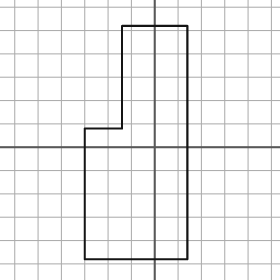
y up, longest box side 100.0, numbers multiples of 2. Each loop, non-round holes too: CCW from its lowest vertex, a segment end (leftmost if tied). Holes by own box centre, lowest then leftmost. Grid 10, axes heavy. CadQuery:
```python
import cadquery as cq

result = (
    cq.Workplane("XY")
    .moveTo(-30.0, -48.0)
    .lineTo(14.0, -48.0)
    .lineTo(14.0, 52.0)
    .lineTo(-14.0, 52.0)
    .lineTo(-14.0, 8.0)
    .lineTo(-30.0, 8.0)
    .close()
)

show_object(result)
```